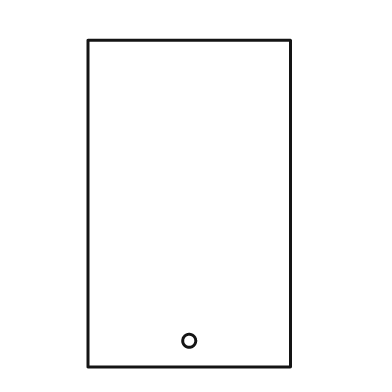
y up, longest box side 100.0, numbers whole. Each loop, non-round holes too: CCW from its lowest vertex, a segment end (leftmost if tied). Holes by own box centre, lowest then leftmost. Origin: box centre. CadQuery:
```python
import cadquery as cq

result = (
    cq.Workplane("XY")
    .moveTo(-31.0, -50.0)
    .lineTo(31.0, -50.0)
    .lineTo(31.0, 50.0)
    .lineTo(-31.0, 50.0)
    .close()
    .moveTo(0.0, -42.0)
    .circle(2.0)
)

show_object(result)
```